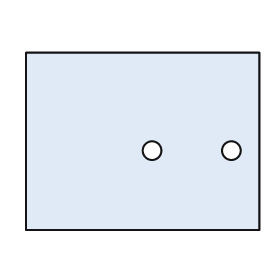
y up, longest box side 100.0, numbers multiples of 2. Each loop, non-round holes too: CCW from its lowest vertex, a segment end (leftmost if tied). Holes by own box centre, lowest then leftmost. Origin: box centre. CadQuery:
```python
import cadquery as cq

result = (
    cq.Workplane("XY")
    .moveTo(-50.0, -38.0)
    .lineTo(50.0, -38.0)
    .lineTo(50.0, 38.0)
    .lineTo(-50.0, 38.0)
    .close()
    .moveTo(4.0, -4.0)
    .circle(4.0)
    .moveTo(38.0, -4.0)
    .circle(4.0)
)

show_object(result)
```